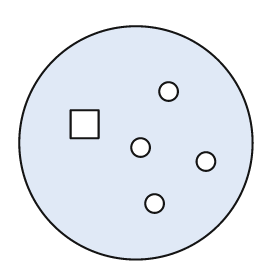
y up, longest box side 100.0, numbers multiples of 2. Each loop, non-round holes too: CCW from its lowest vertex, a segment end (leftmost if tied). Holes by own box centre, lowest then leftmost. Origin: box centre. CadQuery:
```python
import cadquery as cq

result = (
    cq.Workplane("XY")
    .moveTo(0.0, 0.0)
    .circle(50.0)
    .moveTo(8.0, -26.0)
    .circle(4.0)
    .moveTo(30.0, -8.0)
    .circle(4.0)
    .moveTo(2.0, -2.0)
    .circle(4.0)
    .moveTo(-28.0, 2.0)
    .lineTo(-16.0, 2.0)
    .lineTo(-16.0, 14.0)
    .lineTo(-28.0, 14.0)
    .close()
    .moveTo(14.0, 22.0)
    .circle(4.0)
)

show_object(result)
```